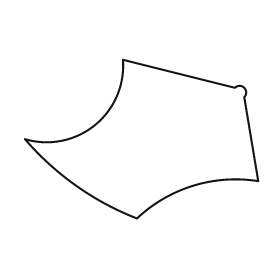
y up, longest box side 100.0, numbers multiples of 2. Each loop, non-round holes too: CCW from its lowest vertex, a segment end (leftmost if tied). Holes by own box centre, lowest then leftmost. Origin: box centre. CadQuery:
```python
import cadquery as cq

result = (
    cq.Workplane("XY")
    .moveTo(-2.0, -34.0)
    .threePointArc((22.0, -20.0), (50.0, -18.0))
    .lineTo(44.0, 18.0)
    .threePointArc((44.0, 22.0), (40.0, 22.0))
    .lineTo(-8.0, 34.0)
    .threePointArc((-20.0, 6.0), (-50.0, 0.0))
    .threePointArc((-28.0, -20.0), (-2.0, -34.0))
    .close()
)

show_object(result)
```